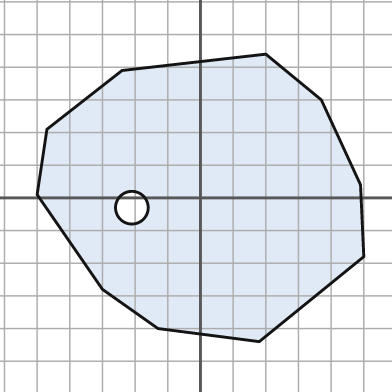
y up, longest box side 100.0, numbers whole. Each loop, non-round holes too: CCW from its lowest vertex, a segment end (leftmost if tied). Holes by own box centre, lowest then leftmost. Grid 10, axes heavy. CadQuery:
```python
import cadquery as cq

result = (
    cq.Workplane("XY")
    .moveTo(18.0, -44.0)
    .lineTo(50.0, -18.0)
    .lineTo(49.0, 4.0)
    .lineTo(37.0, 30.0)
    .lineTo(20.0, 44.0)
    .lineTo(-24.0, 39.0)
    .lineTo(-47.0, 21.0)
    .lineTo(-50.0, 1.0)
    .lineTo(-30.0, -28.0)
    .lineTo(-13.0, -40.0)
    .close()
    .moveTo(-21.0, -3.0)
    .circle(5.0)
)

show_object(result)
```